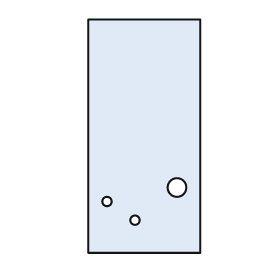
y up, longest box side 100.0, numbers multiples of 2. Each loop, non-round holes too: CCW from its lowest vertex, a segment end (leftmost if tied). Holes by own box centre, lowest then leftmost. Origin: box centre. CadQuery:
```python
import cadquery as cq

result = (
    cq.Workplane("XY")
    .moveTo(-24.0, -50.0)
    .lineTo(24.0, -50.0)
    .lineTo(24.0, 50.0)
    .lineTo(-24.0, 50.0)
    .close()
    .moveTo(-4.0, -36.0)
    .circle(2.0)
    .moveTo(-16.0, -28.0)
    .circle(2.0)
    .moveTo(14.0, -22.0)
    .circle(4.0)
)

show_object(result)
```